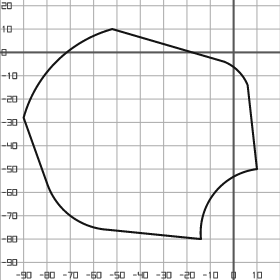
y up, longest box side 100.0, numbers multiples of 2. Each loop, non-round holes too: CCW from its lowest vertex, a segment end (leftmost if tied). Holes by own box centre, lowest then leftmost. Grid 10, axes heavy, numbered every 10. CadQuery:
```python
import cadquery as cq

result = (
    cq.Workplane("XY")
    .moveTo(-14.0, -80.0)
    .threePointArc((-8.0, -60.0), (10.0, -50.0))
    .lineTo(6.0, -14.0)
    .threePointArc((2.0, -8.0), (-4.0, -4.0))
    .lineTo(-52.0, 10.0)
    .threePointArc((-76.0, -4.0), (-90.0, -28.0))
    .lineTo(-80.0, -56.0)
    .threePointArc((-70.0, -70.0), (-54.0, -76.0))
    .close()
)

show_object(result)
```